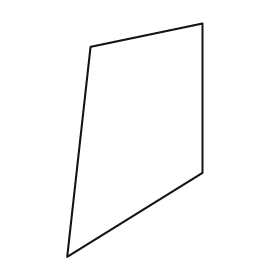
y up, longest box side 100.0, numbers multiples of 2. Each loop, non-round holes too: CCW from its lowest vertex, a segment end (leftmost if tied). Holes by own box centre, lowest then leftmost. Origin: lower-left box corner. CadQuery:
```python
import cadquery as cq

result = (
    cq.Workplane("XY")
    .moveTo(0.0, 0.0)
    .lineTo(58.0, 36.0)
    .lineTo(58.0, 100.0)
    .lineTo(10.0, 90.0)
    .close()
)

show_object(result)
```